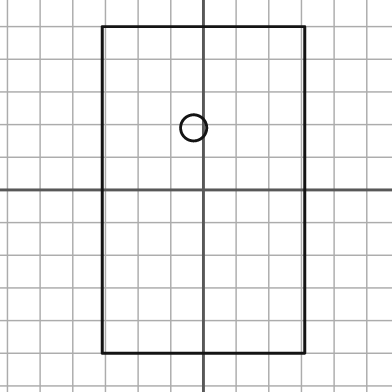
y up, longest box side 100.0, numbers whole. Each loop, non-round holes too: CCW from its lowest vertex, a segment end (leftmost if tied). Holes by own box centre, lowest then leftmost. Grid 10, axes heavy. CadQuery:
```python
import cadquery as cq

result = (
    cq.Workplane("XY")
    .moveTo(-31.0, -50.0)
    .lineTo(31.0, -50.0)
    .lineTo(31.0, 50.0)
    .lineTo(-31.0, 50.0)
    .close()
    .moveTo(-3.0, 19.0)
    .circle(4.0)
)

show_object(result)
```